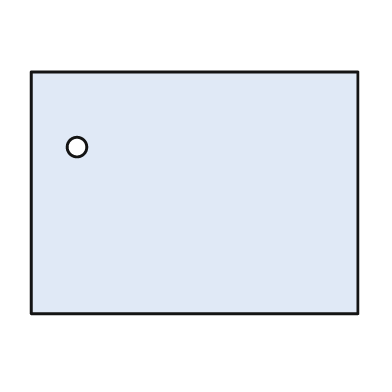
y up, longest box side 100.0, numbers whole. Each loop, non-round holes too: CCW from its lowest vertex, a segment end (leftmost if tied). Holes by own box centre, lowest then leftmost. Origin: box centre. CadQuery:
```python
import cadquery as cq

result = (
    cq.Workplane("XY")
    .moveTo(-50.0, -37.0)
    .lineTo(50.0, -37.0)
    .lineTo(50.0, 37.0)
    .lineTo(-50.0, 37.0)
    .close()
    .moveTo(-36.0, 14.0)
    .circle(3.0)
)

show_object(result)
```